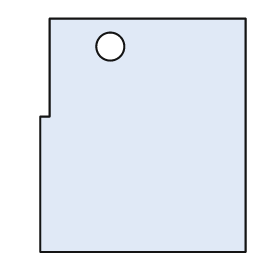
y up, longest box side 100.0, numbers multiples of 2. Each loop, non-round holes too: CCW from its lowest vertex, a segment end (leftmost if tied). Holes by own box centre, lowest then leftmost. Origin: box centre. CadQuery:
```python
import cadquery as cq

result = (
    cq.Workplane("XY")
    .moveTo(-44.0, -50.0)
    .lineTo(44.0, -50.0)
    .lineTo(44.0, 50.0)
    .lineTo(-40.0, 50.0)
    .lineTo(-40.0, 8.0)
    .lineTo(-44.0, 8.0)
    .close()
    .moveTo(-14.0, 38.0)
    .circle(6.0)
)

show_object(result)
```